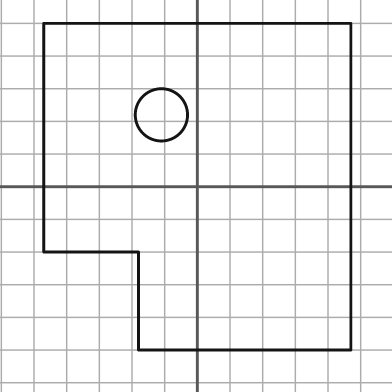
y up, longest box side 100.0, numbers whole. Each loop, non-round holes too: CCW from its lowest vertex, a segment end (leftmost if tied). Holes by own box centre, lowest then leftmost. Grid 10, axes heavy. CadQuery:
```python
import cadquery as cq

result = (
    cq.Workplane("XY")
    .moveTo(-18.0, -50.0)
    .lineTo(47.0, -50.0)
    .lineTo(47.0, 50.0)
    .lineTo(-47.0, 50.0)
    .lineTo(-47.0, -20.0)
    .lineTo(-18.0, -20.0)
    .close()
    .moveTo(-11.0, 22.0)
    .circle(8.0)
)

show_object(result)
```